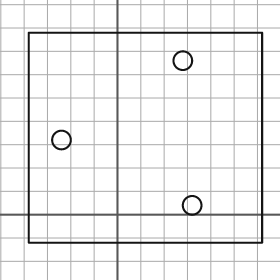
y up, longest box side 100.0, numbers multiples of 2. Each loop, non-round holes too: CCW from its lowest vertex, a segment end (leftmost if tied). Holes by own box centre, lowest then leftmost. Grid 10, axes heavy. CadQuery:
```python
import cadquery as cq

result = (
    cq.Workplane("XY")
    .moveTo(-38.0, -12.0)
    .lineTo(62.0, -12.0)
    .lineTo(62.0, 78.0)
    .lineTo(-38.0, 78.0)
    .close()
    .moveTo(32.0, 4.0)
    .circle(4.0)
    .moveTo(-24.0, 32.0)
    .circle(4.0)
    .moveTo(28.0, 66.0)
    .circle(4.0)
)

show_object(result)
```